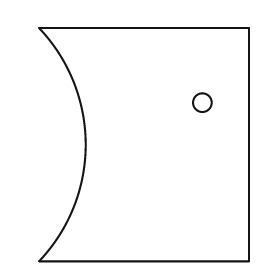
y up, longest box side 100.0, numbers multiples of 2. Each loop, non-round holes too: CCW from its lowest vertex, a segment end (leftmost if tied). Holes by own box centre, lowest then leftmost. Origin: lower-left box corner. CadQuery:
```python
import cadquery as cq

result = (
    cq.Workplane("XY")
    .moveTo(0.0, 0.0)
    .lineTo(90.0, 0.0)
    .lineTo(90.0, 100.0)
    .lineTo(0.0, 100.0)
    .threePointArc((20.0, 50.0), (0.0, 0.0))
    .close()
    .moveTo(70.0, 68.0)
    .circle(4.0)
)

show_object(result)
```